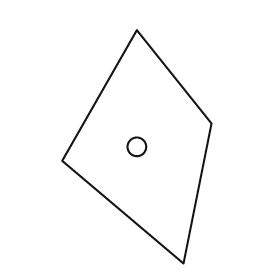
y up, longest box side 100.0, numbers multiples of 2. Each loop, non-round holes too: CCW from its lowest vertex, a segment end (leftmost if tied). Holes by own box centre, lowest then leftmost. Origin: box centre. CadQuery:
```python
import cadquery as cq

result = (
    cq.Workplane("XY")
    .moveTo(20.0, -50.0)
    .lineTo(32.0, 10.0)
    .lineTo(0.0, 50.0)
    .lineTo(-32.0, -6.0)
    .close()
    .moveTo(0.0, 0.0)
    .circle(4.0)
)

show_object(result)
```